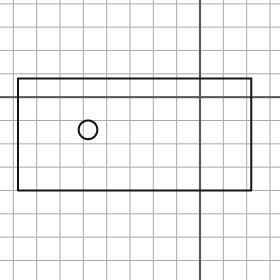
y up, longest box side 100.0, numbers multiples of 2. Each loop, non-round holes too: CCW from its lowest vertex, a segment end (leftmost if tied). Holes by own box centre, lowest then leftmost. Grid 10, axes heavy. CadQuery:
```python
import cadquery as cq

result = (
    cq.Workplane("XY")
    .moveTo(-78.0, -40.0)
    .lineTo(22.0, -40.0)
    .lineTo(22.0, 8.0)
    .lineTo(-78.0, 8.0)
    .close()
    .moveTo(-48.0, -14.0)
    .circle(4.0)
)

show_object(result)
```